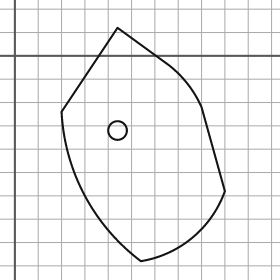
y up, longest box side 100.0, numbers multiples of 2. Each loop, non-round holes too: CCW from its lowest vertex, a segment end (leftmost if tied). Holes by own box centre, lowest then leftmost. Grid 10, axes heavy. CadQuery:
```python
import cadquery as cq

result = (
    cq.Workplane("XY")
    .moveTo(54.0, -88.0)
    .threePointArc((76.0, -78.0), (90.0, -58.0))
    .lineTo(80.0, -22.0)
    .threePointArc((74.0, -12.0), (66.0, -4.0))
    .lineTo(44.0, 12.0)
    .lineTo(20.0, -24.0)
    .threePointArc((30.0, -60.0), (54.0, -88.0))
    .close()
    .moveTo(44.0, -32.0)
    .circle(4.0)
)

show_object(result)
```